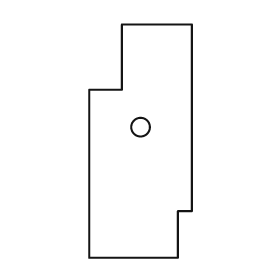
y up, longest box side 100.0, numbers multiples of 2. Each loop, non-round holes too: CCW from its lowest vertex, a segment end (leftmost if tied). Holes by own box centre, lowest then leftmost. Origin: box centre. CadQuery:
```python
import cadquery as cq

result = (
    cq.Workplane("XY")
    .moveTo(-22.0, -50.0)
    .lineTo(16.0, -50.0)
    .lineTo(16.0, -30.0)
    .lineTo(22.0, -30.0)
    .lineTo(22.0, 50.0)
    .lineTo(-8.0, 50.0)
    .lineTo(-8.0, 22.0)
    .lineTo(-22.0, 22.0)
    .close()
    .moveTo(0.0, 6.0)
    .circle(4.0)
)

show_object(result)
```